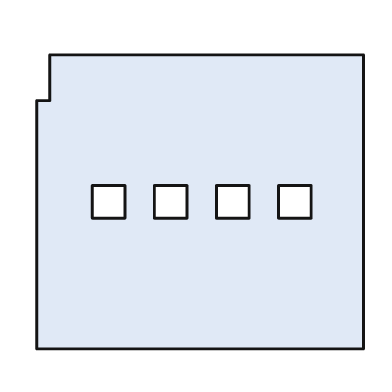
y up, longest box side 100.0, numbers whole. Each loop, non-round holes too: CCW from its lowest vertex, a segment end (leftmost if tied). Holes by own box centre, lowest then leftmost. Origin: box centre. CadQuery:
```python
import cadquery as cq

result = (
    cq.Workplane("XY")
    .moveTo(-50.0, -45.0)
    .lineTo(50.0, -45.0)
    .lineTo(50.0, 45.0)
    .lineTo(-46.0, 45.0)
    .lineTo(-46.0, 31.0)
    .lineTo(-50.0, 31.0)
    .close()
    .moveTo(-33.0, -5.0)
    .lineTo(-23.0, -5.0)
    .lineTo(-23.0, 5.0)
    .lineTo(-33.0, 5.0)
    .close()
    .moveTo(-14.0, -5.0)
    .lineTo(-4.0, -5.0)
    .lineTo(-4.0, 5.0)
    .lineTo(-14.0, 5.0)
    .close()
    .moveTo(5.0, -5.0)
    .lineTo(15.0, -5.0)
    .lineTo(15.0, 5.0)
    .lineTo(5.0, 5.0)
    .close()
    .moveTo(24.0, -5.0)
    .lineTo(34.0, -5.0)
    .lineTo(34.0, 5.0)
    .lineTo(24.0, 5.0)
    .close()
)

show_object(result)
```